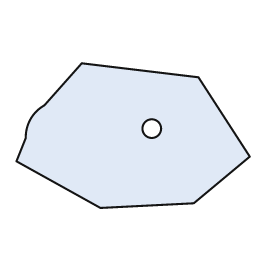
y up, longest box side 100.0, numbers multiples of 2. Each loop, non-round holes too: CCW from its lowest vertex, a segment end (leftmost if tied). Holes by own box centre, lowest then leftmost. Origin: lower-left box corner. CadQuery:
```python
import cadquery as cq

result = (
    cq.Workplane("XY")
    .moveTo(36.0, 0.0)
    .lineTo(76.0, 2.0)
    .lineTo(100.0, 22.0)
    .lineTo(78.0, 56.0)
    .lineTo(28.0, 62.0)
    .lineTo(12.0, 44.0)
    .threePointArc((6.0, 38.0), (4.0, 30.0))
    .lineTo(0.0, 20.0)
    .close()
    .moveTo(58.0, 34.0)
    .circle(4.0)
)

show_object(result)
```